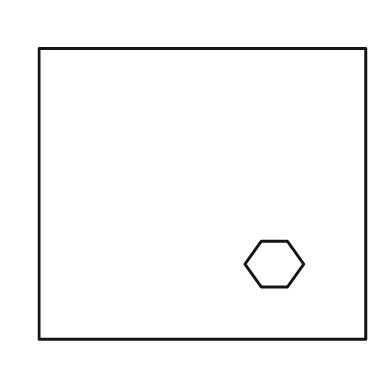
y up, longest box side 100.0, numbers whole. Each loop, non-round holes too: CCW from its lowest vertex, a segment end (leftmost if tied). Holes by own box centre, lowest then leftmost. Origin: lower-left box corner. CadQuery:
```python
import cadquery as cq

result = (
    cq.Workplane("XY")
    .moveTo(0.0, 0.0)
    .lineTo(100.0, 0.0)
    .lineTo(100.0, 89.0)
    .lineTo(0.0, 89.0)
    .close()
    .moveTo(68.0, 16.0)
    .lineTo(76.0, 16.0)
    .lineTo(81.0, 23.0)
    .lineTo(76.0, 30.0)
    .lineTo(68.0, 30.0)
    .lineTo(63.0, 23.0)
    .close()
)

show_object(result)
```